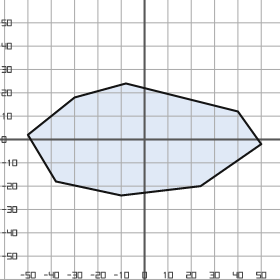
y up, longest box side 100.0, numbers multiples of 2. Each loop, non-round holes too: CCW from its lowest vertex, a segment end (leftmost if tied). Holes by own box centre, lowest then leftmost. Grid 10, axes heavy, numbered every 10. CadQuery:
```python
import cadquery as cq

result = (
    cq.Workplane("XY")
    .moveTo(-10.0, -24.0)
    .lineTo(24.0, -20.0)
    .lineTo(50.0, -2.0)
    .lineTo(40.0, 12.0)
    .lineTo(-8.0, 24.0)
    .lineTo(-30.0, 18.0)
    .lineTo(-50.0, 2.0)
    .lineTo(-38.0, -18.0)
    .close()
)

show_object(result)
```